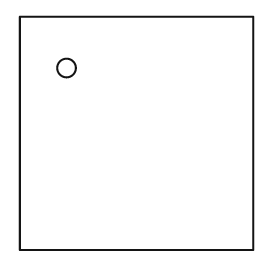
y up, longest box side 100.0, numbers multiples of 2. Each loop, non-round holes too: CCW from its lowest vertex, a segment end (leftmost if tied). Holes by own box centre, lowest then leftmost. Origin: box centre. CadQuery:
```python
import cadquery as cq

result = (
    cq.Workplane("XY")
    .moveTo(-50.0, -50.0)
    .lineTo(50.0, -50.0)
    .lineTo(50.0, 50.0)
    .lineTo(-50.0, 50.0)
    .close()
    .moveTo(-30.0, 28.0)
    .circle(4.0)
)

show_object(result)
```